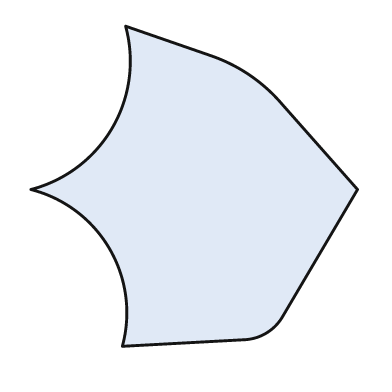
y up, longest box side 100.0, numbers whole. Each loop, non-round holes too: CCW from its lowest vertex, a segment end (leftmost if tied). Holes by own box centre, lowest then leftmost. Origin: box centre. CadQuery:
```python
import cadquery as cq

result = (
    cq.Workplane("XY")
    .moveTo(-22.0, -49.0)
    .lineTo(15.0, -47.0)
    .threePointArc((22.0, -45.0), (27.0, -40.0))
    .lineTo(50.0, -1.0)
    .lineTo(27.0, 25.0)
    .threePointArc((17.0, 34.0), (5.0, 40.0))
    .lineTo(-21.0, 49.0)
    .threePointArc((-25.0, 18.0), (-50.0, -1.0))
    .threePointArc((-26.0, -19.0), (-22.0, -49.0))
    .close()
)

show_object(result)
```